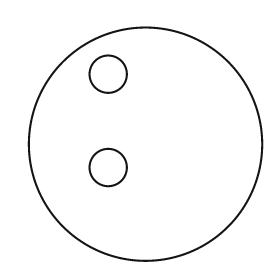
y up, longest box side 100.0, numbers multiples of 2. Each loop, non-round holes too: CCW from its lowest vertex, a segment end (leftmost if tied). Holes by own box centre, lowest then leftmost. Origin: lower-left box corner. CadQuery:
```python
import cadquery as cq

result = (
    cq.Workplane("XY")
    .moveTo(50.0, 50.0)
    .circle(50.0)
    .moveTo(34.0, 40.0)
    .circle(8.0)
    .moveTo(34.0, 80.0)
    .circle(8.0)
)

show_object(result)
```